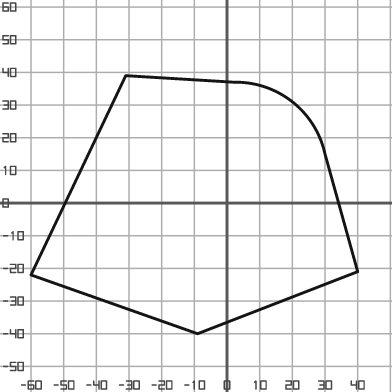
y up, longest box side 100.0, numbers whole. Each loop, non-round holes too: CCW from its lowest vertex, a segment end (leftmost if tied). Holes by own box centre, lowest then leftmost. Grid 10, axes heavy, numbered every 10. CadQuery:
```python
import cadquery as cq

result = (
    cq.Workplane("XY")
    .moveTo(-9.0, -40.0)
    .lineTo(40.0, -21.0)
    .lineTo(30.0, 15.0)
    .threePointArc((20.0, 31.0), (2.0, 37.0))
    .lineTo(-31.0, 39.0)
    .lineTo(-60.0, -22.0)
    .close()
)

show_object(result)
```